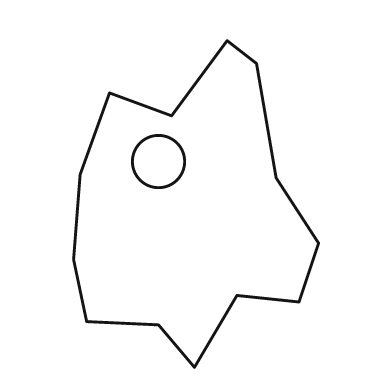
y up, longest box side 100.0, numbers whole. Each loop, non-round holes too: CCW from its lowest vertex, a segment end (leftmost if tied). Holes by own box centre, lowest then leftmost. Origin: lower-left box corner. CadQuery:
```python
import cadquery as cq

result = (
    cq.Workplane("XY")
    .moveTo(37.0, 0.0)
    .lineTo(50.0, 22.0)
    .lineTo(69.0, 20.0)
    .lineTo(75.0, 38.0)
    .lineTo(62.0, 58.0)
    .lineTo(56.0, 93.0)
    .lineTo(47.0, 100.0)
    .lineTo(30.0, 77.0)
    .lineTo(11.0, 84.0)
    .lineTo(2.0, 59.0)
    .lineTo(0.0, 33.0)
    .lineTo(4.0, 14.0)
    .lineTo(26.0, 13.0)
    .close()
    .moveTo(26.0, 63.0)
    .circle(8.0)
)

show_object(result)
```